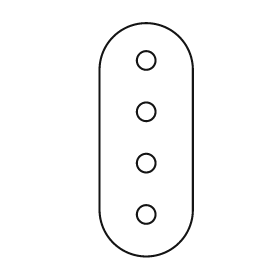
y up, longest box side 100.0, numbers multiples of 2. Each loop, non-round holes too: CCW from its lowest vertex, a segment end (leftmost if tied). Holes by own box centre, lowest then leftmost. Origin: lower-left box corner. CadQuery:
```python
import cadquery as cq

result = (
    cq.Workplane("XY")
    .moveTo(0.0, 20.0)
    .threePointArc((20.0, 0.0), (40.0, 20.0))
    .lineTo(40.0, 80.0)
    .threePointArc((20.0, 100.0), (0.0, 80.0))
    .close()
    .moveTo(20.0, 18.0)
    .circle(4.0)
    .moveTo(20.0, 40.0)
    .circle(4.0)
    .moveTo(20.0, 62.0)
    .circle(4.0)
    .moveTo(20.0, 84.0)
    .circle(4.0)
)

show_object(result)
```